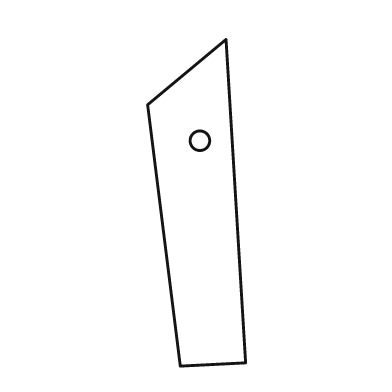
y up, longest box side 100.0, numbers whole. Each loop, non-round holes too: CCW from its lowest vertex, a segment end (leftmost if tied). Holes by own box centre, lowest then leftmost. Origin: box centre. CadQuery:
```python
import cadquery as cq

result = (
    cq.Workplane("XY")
    .moveTo(-5.0, -50.0)
    .lineTo(15.0, -49.0)
    .lineTo(9.0, 50.0)
    .lineTo(-15.0, 30.0)
    .close()
    .moveTo(1.0, 19.0)
    .circle(3.0)
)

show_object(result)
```